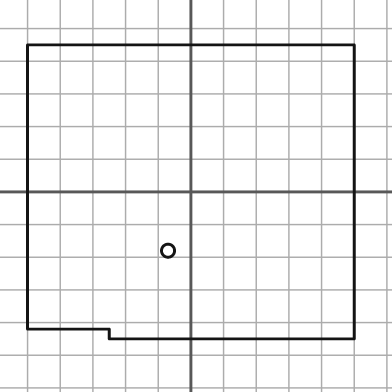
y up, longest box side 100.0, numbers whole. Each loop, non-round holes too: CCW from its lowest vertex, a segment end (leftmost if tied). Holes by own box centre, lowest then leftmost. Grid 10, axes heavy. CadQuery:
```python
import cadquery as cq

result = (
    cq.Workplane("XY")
    .moveTo(-25.0, -45.0)
    .lineTo(50.0, -45.0)
    .lineTo(50.0, 45.0)
    .lineTo(-50.0, 45.0)
    .lineTo(-50.0, -42.0)
    .lineTo(-25.0, -42.0)
    .close()
    .moveTo(-7.0, -18.0)
    .circle(2.0)
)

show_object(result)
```